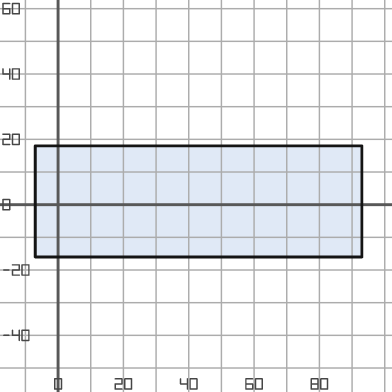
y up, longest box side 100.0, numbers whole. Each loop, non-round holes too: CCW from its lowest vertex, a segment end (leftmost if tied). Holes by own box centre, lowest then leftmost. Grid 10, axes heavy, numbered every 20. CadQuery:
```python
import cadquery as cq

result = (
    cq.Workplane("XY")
    .moveTo(-7.0, -16.0)
    .lineTo(93.0, -16.0)
    .lineTo(93.0, 18.0)
    .lineTo(-7.0, 18.0)
    .close()
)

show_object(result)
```